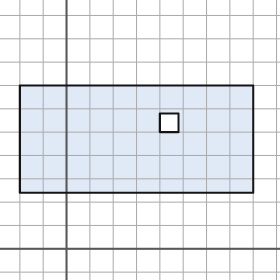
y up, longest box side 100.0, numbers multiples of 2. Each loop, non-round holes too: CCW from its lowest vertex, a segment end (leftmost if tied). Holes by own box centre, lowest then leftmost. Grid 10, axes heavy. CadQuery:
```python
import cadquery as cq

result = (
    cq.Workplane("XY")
    .moveTo(-20.0, 24.0)
    .lineTo(80.0, 24.0)
    .lineTo(80.0, 70.0)
    .lineTo(-20.0, 70.0)
    .close()
    .moveTo(40.0, 50.0)
    .lineTo(48.0, 50.0)
    .lineTo(48.0, 58.0)
    .lineTo(40.0, 58.0)
    .close()
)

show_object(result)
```